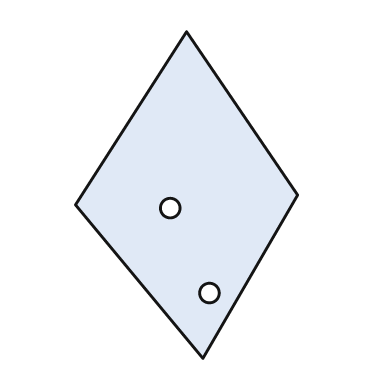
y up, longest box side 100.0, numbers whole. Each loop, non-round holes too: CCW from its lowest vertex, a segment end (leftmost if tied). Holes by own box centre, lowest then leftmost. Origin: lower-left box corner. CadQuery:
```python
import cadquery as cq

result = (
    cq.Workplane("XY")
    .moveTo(39.0, 0.0)
    .lineTo(68.0, 50.0)
    .lineTo(34.0, 100.0)
    .lineTo(0.0, 47.0)
    .close()
    .moveTo(41.0, 20.0)
    .circle(3.0)
    .moveTo(29.0, 46.0)
    .circle(3.0)
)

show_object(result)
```